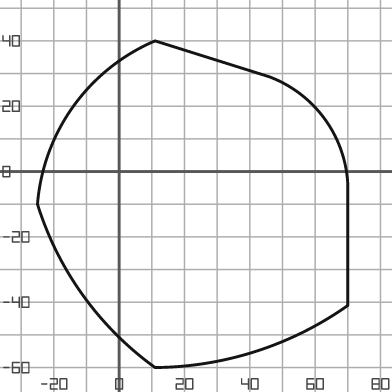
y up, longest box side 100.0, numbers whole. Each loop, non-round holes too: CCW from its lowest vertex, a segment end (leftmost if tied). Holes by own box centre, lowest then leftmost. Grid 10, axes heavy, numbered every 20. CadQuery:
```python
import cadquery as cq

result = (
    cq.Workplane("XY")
    .moveTo(11.0, -60.0)
    .threePointArc((42.0, -55.0), (70.0, -41.0))
    .lineTo(70.0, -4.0)
    .threePointArc((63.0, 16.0), (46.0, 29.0))
    .lineTo(11.0, 40.0)
    .threePointArc((-14.0, 20.0), (-25.0, -10.0))
    .threePointArc((-11.0, -38.0), (11.0, -60.0))
    .close()
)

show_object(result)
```